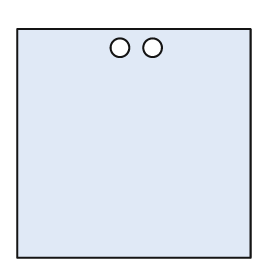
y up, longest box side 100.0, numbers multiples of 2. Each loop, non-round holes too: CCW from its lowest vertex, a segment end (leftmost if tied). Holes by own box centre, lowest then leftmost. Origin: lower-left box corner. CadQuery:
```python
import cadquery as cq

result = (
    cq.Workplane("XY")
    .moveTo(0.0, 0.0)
    .lineTo(100.0, 0.0)
    .lineTo(100.0, 98.0)
    .lineTo(0.0, 98.0)
    .close()
    .moveTo(44.0, 90.0)
    .circle(4.0)
    .moveTo(58.0, 90.0)
    .circle(4.0)
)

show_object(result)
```